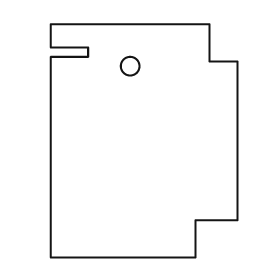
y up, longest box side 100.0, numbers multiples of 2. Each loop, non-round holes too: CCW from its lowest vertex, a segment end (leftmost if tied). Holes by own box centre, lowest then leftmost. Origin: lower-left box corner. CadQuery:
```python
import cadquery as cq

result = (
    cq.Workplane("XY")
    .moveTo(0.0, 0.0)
    .lineTo(62.0, 0.0)
    .lineTo(62.0, 16.0)
    .lineTo(80.0, 16.0)
    .lineTo(80.0, 84.0)
    .lineTo(68.0, 84.0)
    .lineTo(68.0, 100.0)
    .lineTo(0.0, 100.0)
    .lineTo(0.0, 90.0)
    .lineTo(16.0, 90.0)
    .lineTo(16.0, 86.0)
    .lineTo(0.0, 86.0)
    .close()
    .moveTo(34.0, 82.0)
    .circle(4.0)
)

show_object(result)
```